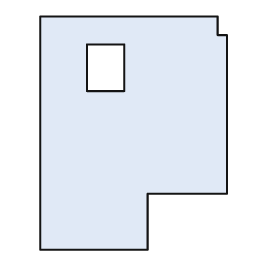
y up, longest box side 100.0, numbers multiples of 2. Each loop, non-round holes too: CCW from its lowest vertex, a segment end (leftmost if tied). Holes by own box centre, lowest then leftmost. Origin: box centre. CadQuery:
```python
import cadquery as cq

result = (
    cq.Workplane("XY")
    .moveTo(-40.0, -50.0)
    .lineTo(6.0, -50.0)
    .lineTo(6.0, -26.0)
    .lineTo(40.0, -26.0)
    .lineTo(40.0, 42.0)
    .lineTo(36.0, 42.0)
    .lineTo(36.0, 50.0)
    .lineTo(-40.0, 50.0)
    .close()
    .moveTo(-20.0, 18.0)
    .lineTo(-4.0, 18.0)
    .lineTo(-4.0, 38.0)
    .lineTo(-20.0, 38.0)
    .close()
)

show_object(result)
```